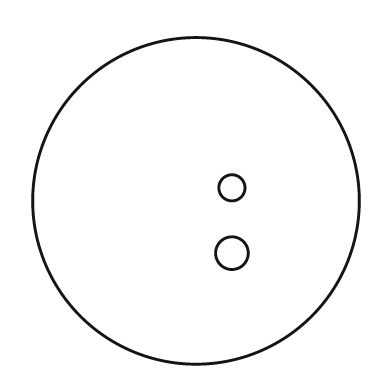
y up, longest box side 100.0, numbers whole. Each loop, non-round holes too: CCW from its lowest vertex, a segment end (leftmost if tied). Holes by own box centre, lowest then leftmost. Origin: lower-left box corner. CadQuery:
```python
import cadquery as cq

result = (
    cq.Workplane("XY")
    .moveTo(50.0, 50.0)
    .circle(50.0)
    .moveTo(61.0, 34.0)
    .circle(5.0)
    .moveTo(61.0, 54.0)
    .circle(4.0)
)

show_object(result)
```